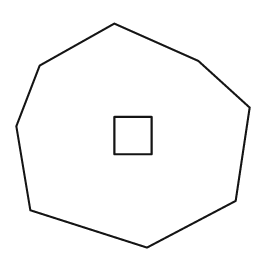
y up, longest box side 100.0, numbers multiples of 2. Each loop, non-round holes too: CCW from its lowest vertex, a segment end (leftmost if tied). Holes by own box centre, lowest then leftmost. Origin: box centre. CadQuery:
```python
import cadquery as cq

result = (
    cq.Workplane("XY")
    .moveTo(6.0, -48.0)
    .lineTo(44.0, -28.0)
    .lineTo(50.0, 12.0)
    .lineTo(28.0, 32.0)
    .lineTo(-8.0, 48.0)
    .lineTo(-40.0, 30.0)
    .lineTo(-50.0, 4.0)
    .lineTo(-44.0, -32.0)
    .close()
    .moveTo(-8.0, -8.0)
    .lineTo(8.0, -8.0)
    .lineTo(8.0, 8.0)
    .lineTo(-8.0, 8.0)
    .close()
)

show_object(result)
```